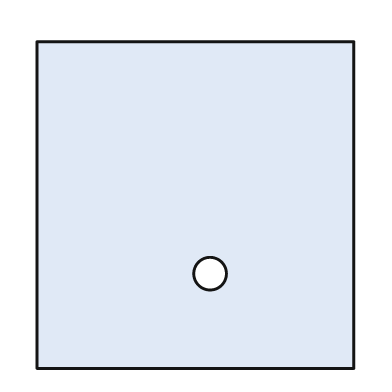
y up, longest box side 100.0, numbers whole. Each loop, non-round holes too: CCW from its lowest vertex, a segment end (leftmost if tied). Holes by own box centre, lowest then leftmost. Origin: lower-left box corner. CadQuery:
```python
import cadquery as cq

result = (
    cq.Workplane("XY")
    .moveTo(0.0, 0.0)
    .lineTo(97.0, 0.0)
    .lineTo(97.0, 100.0)
    .lineTo(0.0, 100.0)
    .close()
    .moveTo(53.0, 29.0)
    .circle(5.0)
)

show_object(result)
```